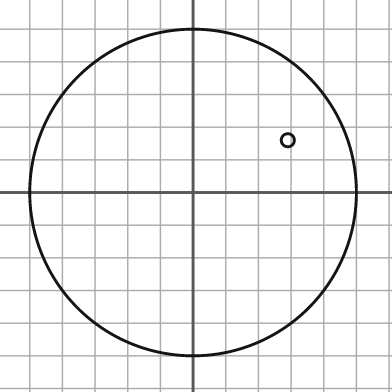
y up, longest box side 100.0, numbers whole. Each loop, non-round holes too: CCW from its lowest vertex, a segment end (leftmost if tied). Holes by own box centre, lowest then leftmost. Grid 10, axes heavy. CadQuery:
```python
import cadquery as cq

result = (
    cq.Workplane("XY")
    .moveTo(0.0, 0.0)
    .circle(50.0)
    .moveTo(29.0, 16.0)
    .circle(2.0)
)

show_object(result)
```